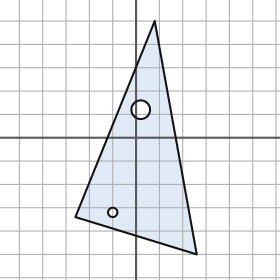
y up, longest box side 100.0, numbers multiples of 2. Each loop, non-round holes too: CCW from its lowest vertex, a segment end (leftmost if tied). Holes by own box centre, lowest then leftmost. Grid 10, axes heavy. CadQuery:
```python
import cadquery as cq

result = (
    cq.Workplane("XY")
    .moveTo(26.0, -50.0)
    .lineTo(8.0, 50.0)
    .lineTo(-26.0, -34.0)
    .close()
    .moveTo(-10.0, -32.0)
    .circle(2.0)
    .moveTo(2.0, 12.0)
    .circle(4.0)
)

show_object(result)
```